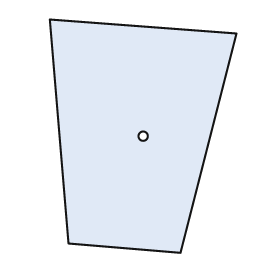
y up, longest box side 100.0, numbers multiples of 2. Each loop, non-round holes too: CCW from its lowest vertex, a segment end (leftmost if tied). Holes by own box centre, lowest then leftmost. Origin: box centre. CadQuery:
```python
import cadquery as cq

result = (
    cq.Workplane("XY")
    .moveTo(16.0, -50.0)
    .lineTo(40.0, 44.0)
    .lineTo(-40.0, 50.0)
    .lineTo(-32.0, -46.0)
    .close()
    .moveTo(0.0, 0.0)
    .circle(2.0)
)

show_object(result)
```